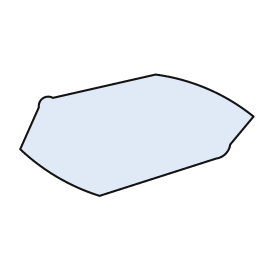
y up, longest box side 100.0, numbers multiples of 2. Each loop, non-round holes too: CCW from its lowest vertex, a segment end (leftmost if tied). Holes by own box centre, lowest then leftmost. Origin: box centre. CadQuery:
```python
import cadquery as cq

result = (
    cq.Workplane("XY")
    .moveTo(-16.0, -26.0)
    .lineTo(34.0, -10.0)
    .threePointArc((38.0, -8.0), (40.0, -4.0))
    .lineTo(50.0, 8.0)
    .threePointArc((30.0, 20.0), (8.0, 26.0))
    .lineTo(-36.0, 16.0)
    .threePointArc((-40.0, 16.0), (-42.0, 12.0))
    .lineTo(-50.0, -6.0)
    .threePointArc((-34.0, -18.0), (-16.0, -26.0))
    .close()
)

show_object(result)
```